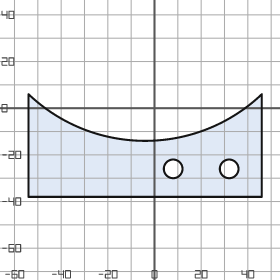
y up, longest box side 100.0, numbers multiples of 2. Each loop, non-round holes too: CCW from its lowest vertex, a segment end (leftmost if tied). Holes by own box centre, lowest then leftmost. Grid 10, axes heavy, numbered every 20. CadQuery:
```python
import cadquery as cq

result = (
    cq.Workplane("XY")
    .moveTo(-54.0, -38.0)
    .lineTo(46.0, -38.0)
    .lineTo(46.0, 6.0)
    .threePointArc((-4.0, -14.0), (-54.0, 6.0))
    .close()
    .moveTo(8.0, -26.0)
    .circle(4.0)
    .moveTo(32.0, -26.0)
    .circle(4.0)
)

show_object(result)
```